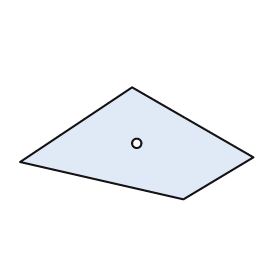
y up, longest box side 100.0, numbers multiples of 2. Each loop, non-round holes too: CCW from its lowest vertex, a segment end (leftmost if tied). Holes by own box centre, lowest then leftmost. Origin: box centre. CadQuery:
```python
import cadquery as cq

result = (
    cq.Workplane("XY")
    .moveTo(20.0, -24.0)
    .lineTo(50.0, -6.0)
    .lineTo(-2.0, 24.0)
    .lineTo(-50.0, -8.0)
    .close()
    .moveTo(0.0, 0.0)
    .circle(2.0)
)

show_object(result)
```